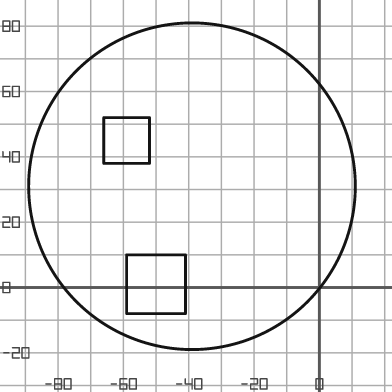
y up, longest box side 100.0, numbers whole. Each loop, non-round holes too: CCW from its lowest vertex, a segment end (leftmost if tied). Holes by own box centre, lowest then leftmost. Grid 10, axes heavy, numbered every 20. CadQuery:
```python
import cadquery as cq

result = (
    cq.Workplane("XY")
    .moveTo(-39.0, 31.0)
    .circle(50.0)
    .moveTo(-59.0, -8.0)
    .lineTo(-41.0, -8.0)
    .lineTo(-41.0, 10.0)
    .lineTo(-59.0, 10.0)
    .close()
    .moveTo(-66.0, 38.0)
    .lineTo(-52.0, 38.0)
    .lineTo(-52.0, 52.0)
    .lineTo(-66.0, 52.0)
    .close()
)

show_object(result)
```